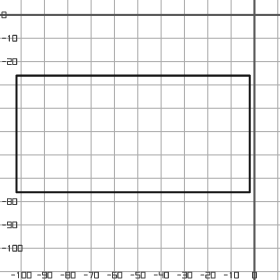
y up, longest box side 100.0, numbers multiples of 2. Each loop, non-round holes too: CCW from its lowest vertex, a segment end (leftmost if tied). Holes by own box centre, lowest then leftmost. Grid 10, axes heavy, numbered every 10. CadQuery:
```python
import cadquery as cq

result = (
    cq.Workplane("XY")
    .moveTo(-102.0, -76.0)
    .lineTo(-2.0, -76.0)
    .lineTo(-2.0, -26.0)
    .lineTo(-102.0, -26.0)
    .close()
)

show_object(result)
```